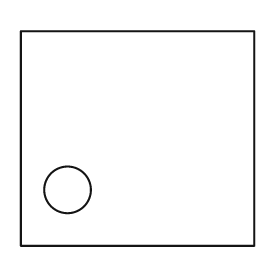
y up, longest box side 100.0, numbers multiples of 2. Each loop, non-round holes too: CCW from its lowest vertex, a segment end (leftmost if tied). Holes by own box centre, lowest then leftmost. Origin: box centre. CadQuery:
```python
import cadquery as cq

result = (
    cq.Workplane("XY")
    .moveTo(-50.0, -46.0)
    .lineTo(50.0, -46.0)
    .lineTo(50.0, 46.0)
    .lineTo(-50.0, 46.0)
    .close()
    .moveTo(-30.0, -22.0)
    .circle(10.0)
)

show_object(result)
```